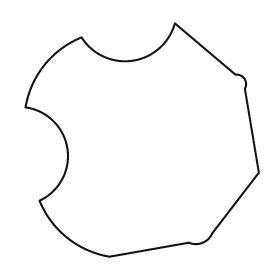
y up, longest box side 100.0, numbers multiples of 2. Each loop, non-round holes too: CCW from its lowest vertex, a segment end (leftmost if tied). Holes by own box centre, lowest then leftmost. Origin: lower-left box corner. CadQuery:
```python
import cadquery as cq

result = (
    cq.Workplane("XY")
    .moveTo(36.0, 0.0)
    .lineTo(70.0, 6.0)
    .threePointArc((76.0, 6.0), (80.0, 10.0))
    .lineTo(100.0, 36.0)
    .lineTo(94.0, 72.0)
    .threePointArc((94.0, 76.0), (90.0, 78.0))
    .lineTo(64.0, 100.0)
    .threePointArc((46.0, 84.0), (24.0, 94.0))
    .threePointArc((8.0, 82.0), (0.0, 64.0))
    .threePointArc((18.0, 46.0), (6.0, 24.0))
    .threePointArc((18.0, 8.0), (36.0, 0.0))
    .close()
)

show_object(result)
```